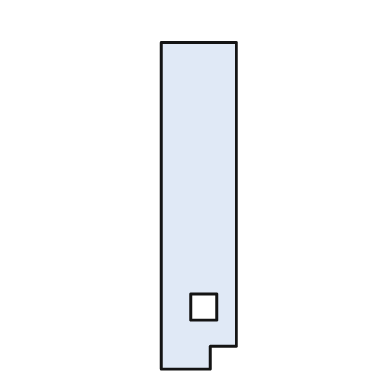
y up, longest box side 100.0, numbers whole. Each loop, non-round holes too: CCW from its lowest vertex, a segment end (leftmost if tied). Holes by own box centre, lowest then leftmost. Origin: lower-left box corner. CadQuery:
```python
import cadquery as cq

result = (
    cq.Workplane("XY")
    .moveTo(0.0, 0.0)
    .lineTo(15.0, 0.0)
    .lineTo(15.0, 7.0)
    .lineTo(23.0, 7.0)
    .lineTo(23.0, 100.0)
    .lineTo(0.0, 100.0)
    .close()
    .moveTo(9.0, 15.0)
    .lineTo(17.0, 15.0)
    .lineTo(17.0, 23.0)
    .lineTo(9.0, 23.0)
    .close()
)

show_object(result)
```